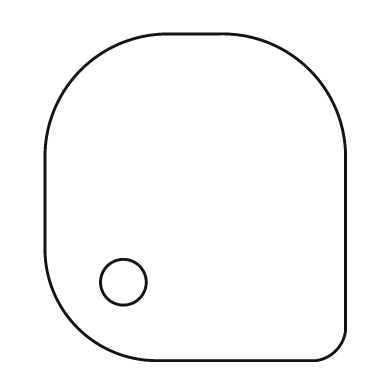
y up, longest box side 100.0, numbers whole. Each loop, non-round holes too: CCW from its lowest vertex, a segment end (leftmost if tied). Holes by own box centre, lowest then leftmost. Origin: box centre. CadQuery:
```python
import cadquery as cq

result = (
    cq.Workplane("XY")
    .moveTo(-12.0, -50.0)
    .lineTo(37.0, -50.0)
    .threePointArc((43.0, -47.0), (46.0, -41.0))
    .lineTo(46.0, 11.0)
    .threePointArc((35.0, 39.0), (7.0, 50.0))
    .lineTo(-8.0, 50.0)
    .threePointArc((-35.0, 39.0), (-46.0, 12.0))
    .lineTo(-46.0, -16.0)
    .threePointArc((-36.0, -40.0), (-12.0, -50.0))
    .close()
    .moveTo(-22.0, -26.0)
    .circle(7.0)
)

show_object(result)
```